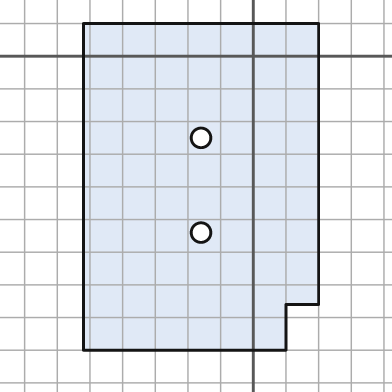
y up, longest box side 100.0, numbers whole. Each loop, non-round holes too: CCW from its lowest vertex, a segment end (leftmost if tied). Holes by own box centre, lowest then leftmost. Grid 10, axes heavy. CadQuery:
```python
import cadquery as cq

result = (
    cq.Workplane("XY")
    .moveTo(-52.0, -90.0)
    .lineTo(10.0, -90.0)
    .lineTo(10.0, -76.0)
    .lineTo(20.0, -76.0)
    .lineTo(20.0, 10.0)
    .lineTo(-52.0, 10.0)
    .close()
    .moveTo(-16.0, -54.0)
    .circle(3.0)
    .moveTo(-16.0, -25.0)
    .circle(3.0)
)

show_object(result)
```